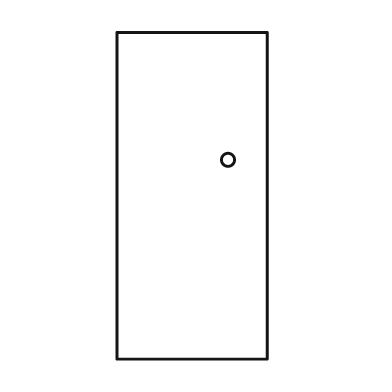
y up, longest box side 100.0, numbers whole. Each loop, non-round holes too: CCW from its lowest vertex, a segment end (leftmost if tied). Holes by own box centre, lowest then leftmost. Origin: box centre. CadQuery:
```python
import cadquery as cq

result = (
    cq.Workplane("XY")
    .moveTo(-23.0, -50.0)
    .lineTo(23.0, -50.0)
    .lineTo(23.0, 50.0)
    .lineTo(-23.0, 50.0)
    .close()
    .moveTo(11.0, 11.0)
    .circle(2.0)
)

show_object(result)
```